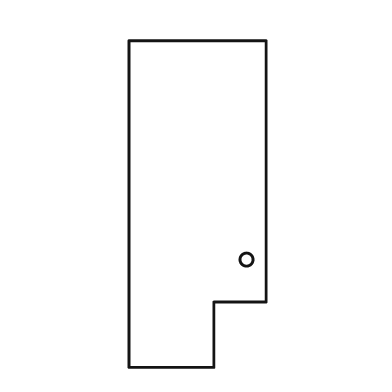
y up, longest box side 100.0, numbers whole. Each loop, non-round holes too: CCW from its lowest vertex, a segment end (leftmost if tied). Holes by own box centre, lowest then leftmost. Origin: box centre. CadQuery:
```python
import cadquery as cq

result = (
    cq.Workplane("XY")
    .moveTo(-21.0, -50.0)
    .lineTo(5.0, -50.0)
    .lineTo(5.0, -30.0)
    .lineTo(21.0, -30.0)
    .lineTo(21.0, 50.0)
    .lineTo(-21.0, 50.0)
    .close()
    .moveTo(15.0, -17.0)
    .circle(2.0)
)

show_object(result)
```